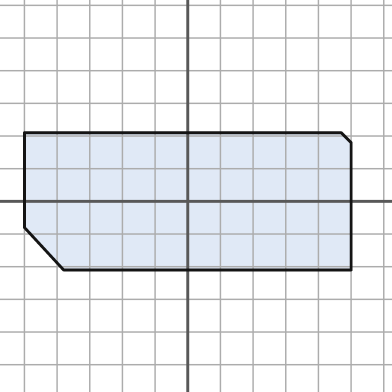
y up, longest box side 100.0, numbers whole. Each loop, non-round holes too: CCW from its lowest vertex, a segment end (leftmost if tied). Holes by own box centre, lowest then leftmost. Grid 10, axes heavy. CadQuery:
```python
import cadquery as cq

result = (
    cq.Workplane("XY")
    .moveTo(-38.0, -21.0)
    .lineTo(50.0, -21.0)
    .lineTo(50.0, 18.0)
    .lineTo(47.0, 21.0)
    .lineTo(-50.0, 21.0)
    .lineTo(-50.0, -8.0)
    .close()
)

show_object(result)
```